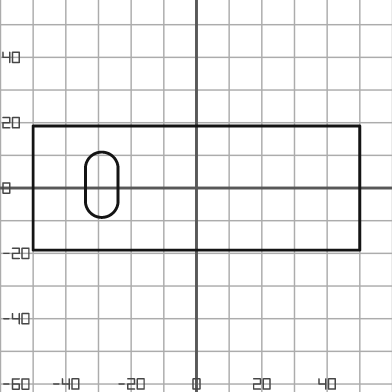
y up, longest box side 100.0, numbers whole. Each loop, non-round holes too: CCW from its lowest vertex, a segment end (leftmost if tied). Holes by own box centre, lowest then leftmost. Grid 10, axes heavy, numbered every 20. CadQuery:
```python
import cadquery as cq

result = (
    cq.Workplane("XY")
    .moveTo(-50.0, -19.0)
    .lineTo(50.0, -19.0)
    .lineTo(50.0, 19.0)
    .lineTo(-50.0, 19.0)
    .close()
    .moveTo(-34.0, -4.0)
    .threePointArc((-29.0, -9.0), (-24.0, -4.0))
    .lineTo(-24.0, 6.0)
    .threePointArc((-29.0, 11.0), (-34.0, 6.0))
    .close()
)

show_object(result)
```